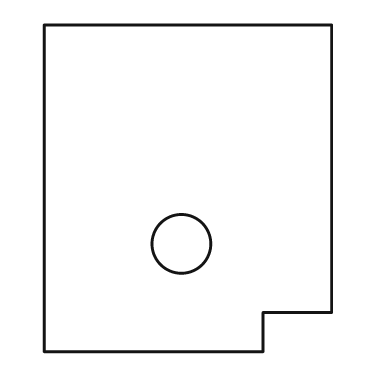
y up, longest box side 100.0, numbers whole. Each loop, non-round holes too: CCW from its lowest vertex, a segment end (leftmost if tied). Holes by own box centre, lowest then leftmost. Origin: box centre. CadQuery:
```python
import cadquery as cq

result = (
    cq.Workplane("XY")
    .moveTo(-44.0, -50.0)
    .lineTo(23.0, -50.0)
    .lineTo(23.0, -38.0)
    .lineTo(44.0, -38.0)
    .lineTo(44.0, 50.0)
    .lineTo(-44.0, 50.0)
    .close()
    .moveTo(-2.0, -17.0)
    .circle(9.0)
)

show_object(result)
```